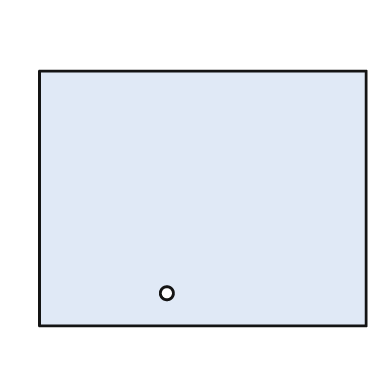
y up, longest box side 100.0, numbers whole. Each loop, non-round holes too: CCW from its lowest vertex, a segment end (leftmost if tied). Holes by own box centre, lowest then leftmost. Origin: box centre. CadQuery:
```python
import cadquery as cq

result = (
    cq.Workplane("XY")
    .moveTo(-50.0, -39.0)
    .lineTo(50.0, -39.0)
    .lineTo(50.0, 39.0)
    .lineTo(-50.0, 39.0)
    .close()
    .moveTo(-11.0, -29.0)
    .circle(2.0)
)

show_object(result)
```